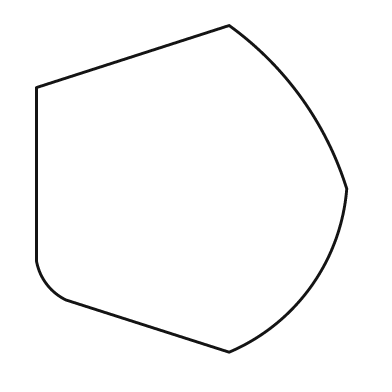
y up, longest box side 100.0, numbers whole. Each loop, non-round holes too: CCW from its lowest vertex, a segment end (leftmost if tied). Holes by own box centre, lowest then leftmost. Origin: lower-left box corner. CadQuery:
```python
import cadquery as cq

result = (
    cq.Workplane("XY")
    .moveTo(59.0, 0.0)
    .threePointArc((84.0, 20.0), (95.0, 50.0))
    .threePointArc((81.0, 78.0), (59.0, 100.0))
    .lineTo(0.0, 81.0)
    .lineTo(0.0, 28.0)
    .threePointArc((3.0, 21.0), (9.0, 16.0))
    .close()
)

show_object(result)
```